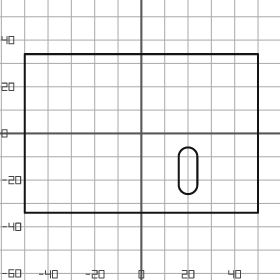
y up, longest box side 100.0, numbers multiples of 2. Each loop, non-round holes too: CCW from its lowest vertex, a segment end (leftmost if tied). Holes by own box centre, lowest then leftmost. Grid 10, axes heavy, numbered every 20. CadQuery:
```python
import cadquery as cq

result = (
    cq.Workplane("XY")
    .moveTo(-50.0, -34.0)
    .lineTo(50.0, -34.0)
    .lineTo(50.0, 34.0)
    .lineTo(-50.0, 34.0)
    .close()
    .moveTo(16.0, -22.0)
    .threePointArc((20.0, -26.0), (24.0, -22.0))
    .lineTo(24.0, -10.0)
    .threePointArc((20.0, -6.0), (16.0, -10.0))
    .close()
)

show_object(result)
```